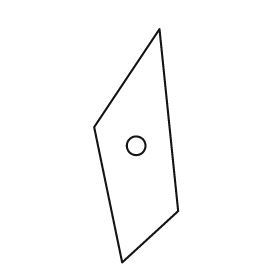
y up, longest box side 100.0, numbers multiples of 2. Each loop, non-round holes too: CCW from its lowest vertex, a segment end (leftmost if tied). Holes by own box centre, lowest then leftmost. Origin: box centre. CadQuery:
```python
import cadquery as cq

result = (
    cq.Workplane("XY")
    .moveTo(-6.0, -50.0)
    .lineTo(18.0, -28.0)
    .lineTo(10.0, 50.0)
    .lineTo(-18.0, 8.0)
    .close()
    .moveTo(0.0, 0.0)
    .circle(4.0)
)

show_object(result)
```